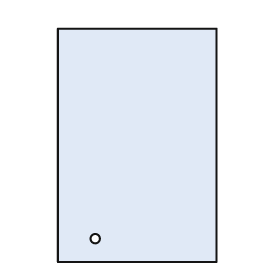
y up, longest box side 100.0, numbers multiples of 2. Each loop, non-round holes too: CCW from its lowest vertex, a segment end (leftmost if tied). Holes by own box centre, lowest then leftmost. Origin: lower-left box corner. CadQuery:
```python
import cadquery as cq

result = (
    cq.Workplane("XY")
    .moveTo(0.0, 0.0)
    .lineTo(68.0, 0.0)
    .lineTo(68.0, 100.0)
    .lineTo(0.0, 100.0)
    .close()
    .moveTo(16.0, 10.0)
    .circle(2.0)
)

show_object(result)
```